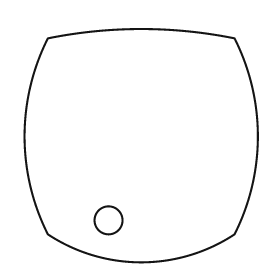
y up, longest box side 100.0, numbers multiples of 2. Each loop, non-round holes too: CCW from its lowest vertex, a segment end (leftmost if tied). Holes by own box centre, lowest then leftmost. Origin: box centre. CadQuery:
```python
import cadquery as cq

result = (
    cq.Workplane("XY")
    .moveTo(-40.0, -38.0)
    .threePointArc((0.0, -50.0), (40.0, -38.0))
    .threePointArc((50.0, 4.0), (40.0, 46.0))
    .threePointArc((0.0, 50.0), (-40.0, 46.0))
    .threePointArc((-50.0, 4.0), (-40.0, -38.0))
    .close()
    .moveTo(-14.0, -32.0)
    .circle(6.0)
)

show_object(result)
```